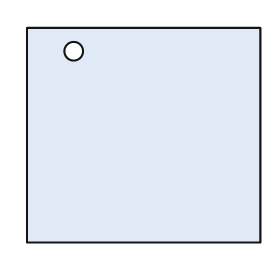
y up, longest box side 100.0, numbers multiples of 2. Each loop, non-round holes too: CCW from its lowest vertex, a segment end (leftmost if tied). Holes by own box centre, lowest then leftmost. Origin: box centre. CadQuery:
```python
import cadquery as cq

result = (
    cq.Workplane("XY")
    .moveTo(-50.0, -46.0)
    .lineTo(50.0, -46.0)
    .lineTo(50.0, 46.0)
    .lineTo(-50.0, 46.0)
    .close()
    .moveTo(-30.0, 36.0)
    .circle(4.0)
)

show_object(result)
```